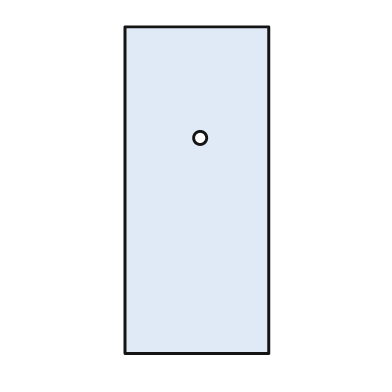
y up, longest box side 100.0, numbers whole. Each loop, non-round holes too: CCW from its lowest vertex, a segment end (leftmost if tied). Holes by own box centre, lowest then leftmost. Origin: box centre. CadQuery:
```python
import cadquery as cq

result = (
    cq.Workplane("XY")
    .moveTo(-22.0, -50.0)
    .lineTo(22.0, -50.0)
    .lineTo(22.0, 50.0)
    .lineTo(-22.0, 50.0)
    .close()
    .moveTo(1.0, 16.0)
    .circle(2.0)
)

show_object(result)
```